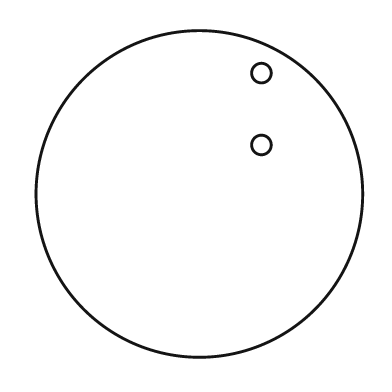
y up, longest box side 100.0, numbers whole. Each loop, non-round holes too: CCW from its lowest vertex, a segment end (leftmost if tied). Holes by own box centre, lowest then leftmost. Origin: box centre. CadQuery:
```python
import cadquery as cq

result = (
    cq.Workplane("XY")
    .moveTo(0.0, 0.0)
    .circle(50.0)
    .moveTo(19.0, 15.0)
    .circle(3.0)
    .moveTo(19.0, 37.0)
    .circle(3.0)
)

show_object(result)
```